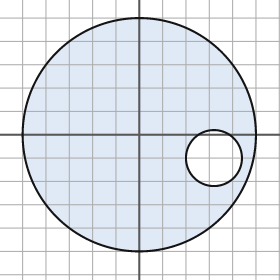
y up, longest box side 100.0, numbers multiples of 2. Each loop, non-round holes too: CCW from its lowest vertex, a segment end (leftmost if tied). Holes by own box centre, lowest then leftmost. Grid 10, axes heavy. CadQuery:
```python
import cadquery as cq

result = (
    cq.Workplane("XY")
    .moveTo(0.0, 0.0)
    .circle(50.0)
    .moveTo(32.0, -10.0)
    .circle(12.0)
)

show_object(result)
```